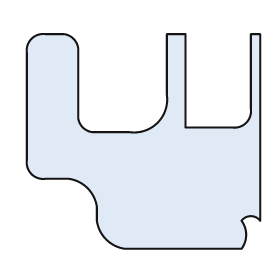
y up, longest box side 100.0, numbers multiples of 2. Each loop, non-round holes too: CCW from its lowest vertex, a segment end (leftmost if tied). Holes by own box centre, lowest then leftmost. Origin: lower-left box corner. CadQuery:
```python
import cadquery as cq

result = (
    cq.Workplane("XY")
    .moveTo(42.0, 0.0)
    .lineTo(92.0, 0.0)
    .threePointArc((94.0, 6.0), (92.0, 12.0))
    .threePointArc((96.0, 14.0), (100.0, 12.0))
    .lineTo(100.0, 92.0)
    .lineTo(96.0, 92.0)
    .lineTo(96.0, 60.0)
    .threePointArc((94.0, 54.0), (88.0, 52.0))
    .lineTo(68.0, 52.0)
    .lineTo(68.0, 92.0)
    .lineTo(60.0, 92.0)
    .lineTo(60.0, 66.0)
    .threePointArc((56.0, 54.0), (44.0, 50.0))
    .lineTo(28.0, 50.0)
    .threePointArc((24.0, 52.0), (22.0, 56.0))
    .lineTo(22.0, 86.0)
    .threePointArc((20.0, 90.0), (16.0, 92.0))
    .lineTo(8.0, 92.0)
    .threePointArc((2.0, 90.0), (0.0, 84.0))
    .lineTo(0.0, 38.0)
    .threePointArc((2.0, 32.0), (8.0, 30.0))
    .lineTo(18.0, 30.0)
    .threePointArc((26.0, 26.0), (30.0, 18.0))
    .lineTo(30.0, 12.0)
    .threePointArc((34.0, 4.0), (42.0, 0.0))
    .close()
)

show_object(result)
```